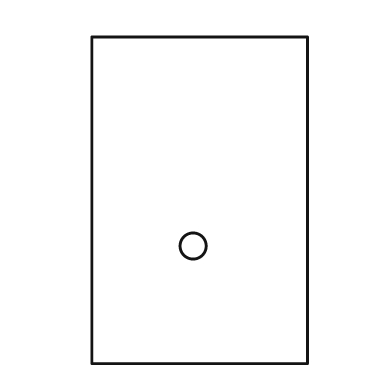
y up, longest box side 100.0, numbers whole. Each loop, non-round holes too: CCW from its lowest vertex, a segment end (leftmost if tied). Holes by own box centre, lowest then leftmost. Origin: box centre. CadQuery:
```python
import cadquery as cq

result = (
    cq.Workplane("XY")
    .moveTo(-33.0, -50.0)
    .lineTo(33.0, -50.0)
    .lineTo(33.0, 50.0)
    .lineTo(-33.0, 50.0)
    .close()
    .moveTo(-2.0, -14.0)
    .circle(4.0)
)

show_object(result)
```